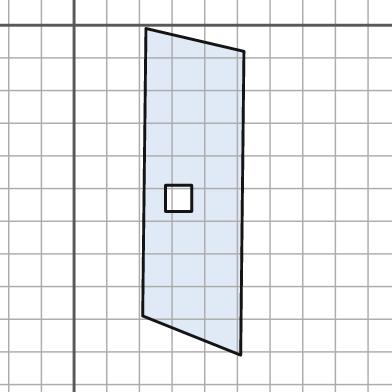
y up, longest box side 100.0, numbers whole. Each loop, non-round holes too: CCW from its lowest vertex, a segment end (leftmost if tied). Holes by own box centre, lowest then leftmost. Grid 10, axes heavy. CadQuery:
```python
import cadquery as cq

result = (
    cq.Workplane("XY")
    .moveTo(51.0, -101.0)
    .lineTo(52.0, -8.0)
    .lineTo(22.0, -1.0)
    .lineTo(21.0, -89.0)
    .close()
    .moveTo(28.0, -57.0)
    .lineTo(36.0, -57.0)
    .lineTo(36.0, -49.0)
    .lineTo(28.0, -49.0)
    .close()
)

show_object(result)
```